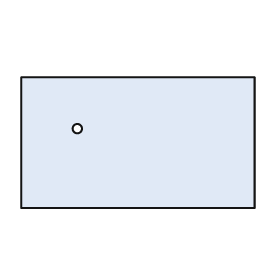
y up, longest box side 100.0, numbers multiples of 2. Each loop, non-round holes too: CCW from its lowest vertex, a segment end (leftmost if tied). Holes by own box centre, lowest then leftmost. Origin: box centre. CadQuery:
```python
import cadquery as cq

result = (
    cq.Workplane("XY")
    .moveTo(-50.0, -28.0)
    .lineTo(50.0, -28.0)
    .lineTo(50.0, 28.0)
    .lineTo(-50.0, 28.0)
    .close()
    .moveTo(-26.0, 6.0)
    .circle(2.0)
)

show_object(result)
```